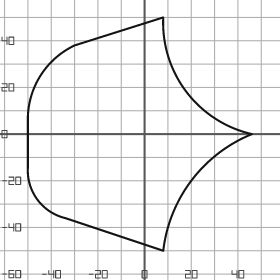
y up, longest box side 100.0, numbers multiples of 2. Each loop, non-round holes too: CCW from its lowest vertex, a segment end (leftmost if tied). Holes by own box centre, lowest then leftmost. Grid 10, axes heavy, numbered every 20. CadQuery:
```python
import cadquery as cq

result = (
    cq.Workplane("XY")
    .moveTo(8.0, -50.0)
    .threePointArc((20.0, -20.0), (46.0, 0.0))
    .threePointArc((18.0, 18.0), (8.0, 50.0))
    .lineTo(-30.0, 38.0)
    .threePointArc((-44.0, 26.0), (-50.0, 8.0))
    .lineTo(-50.0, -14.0)
    .threePointArc((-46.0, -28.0), (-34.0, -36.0))
    .close()
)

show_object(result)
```